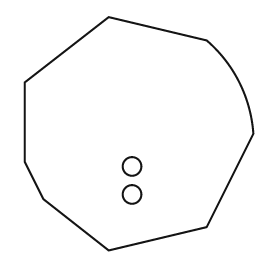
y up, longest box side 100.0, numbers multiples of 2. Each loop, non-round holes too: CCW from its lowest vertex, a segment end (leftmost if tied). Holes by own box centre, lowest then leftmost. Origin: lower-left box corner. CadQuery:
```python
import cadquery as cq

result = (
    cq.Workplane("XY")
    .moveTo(36.0, 0.0)
    .lineTo(78.0, 10.0)
    .lineTo(98.0, 50.0)
    .threePointArc((92.0, 72.0), (78.0, 90.0))
    .lineTo(36.0, 100.0)
    .lineTo(0.0, 72.0)
    .lineTo(0.0, 38.0)
    .lineTo(8.0, 22.0)
    .close()
    .moveTo(46.0, 24.0)
    .circle(4.0)
    .moveTo(46.0, 36.0)
    .circle(4.0)
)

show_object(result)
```